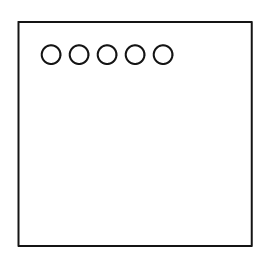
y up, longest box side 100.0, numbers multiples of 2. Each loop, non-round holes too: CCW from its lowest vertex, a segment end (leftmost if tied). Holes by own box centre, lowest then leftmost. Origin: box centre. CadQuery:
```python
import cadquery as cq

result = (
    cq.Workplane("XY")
    .moveTo(-50.0, -48.0)
    .lineTo(50.0, -48.0)
    .lineTo(50.0, 48.0)
    .lineTo(-50.0, 48.0)
    .close()
    .moveTo(-36.0, 34.0)
    .circle(4.0)
    .moveTo(-24.0, 34.0)
    .circle(4.0)
    .moveTo(-12.0, 34.0)
    .circle(4.0)
    .moveTo(0.0, 34.0)
    .circle(4.0)
    .moveTo(12.0, 34.0)
    .circle(4.0)
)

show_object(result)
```